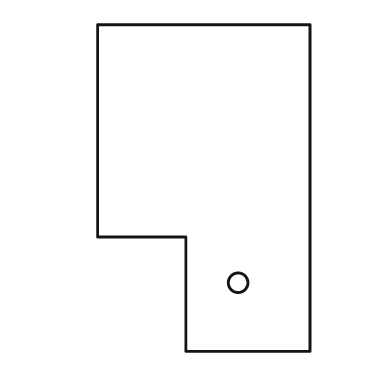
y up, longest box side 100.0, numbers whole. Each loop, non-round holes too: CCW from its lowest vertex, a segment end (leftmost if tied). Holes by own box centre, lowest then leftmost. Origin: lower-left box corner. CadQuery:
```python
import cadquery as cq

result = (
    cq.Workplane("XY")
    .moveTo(27.0, 0.0)
    .lineTo(65.0, 0.0)
    .lineTo(65.0, 100.0)
    .lineTo(0.0, 100.0)
    .lineTo(0.0, 35.0)
    .lineTo(27.0, 35.0)
    .close()
    .moveTo(43.0, 21.0)
    .circle(3.0)
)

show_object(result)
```